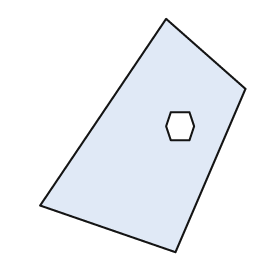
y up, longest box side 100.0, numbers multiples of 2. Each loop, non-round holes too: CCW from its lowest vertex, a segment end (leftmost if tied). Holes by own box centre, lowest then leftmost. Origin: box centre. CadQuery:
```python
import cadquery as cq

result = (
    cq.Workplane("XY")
    .moveTo(14.0, -50.0)
    .lineTo(44.0, 20.0)
    .lineTo(10.0, 50.0)
    .lineTo(-44.0, -30.0)
    .close()
    .moveTo(12.0, -2.0)
    .lineTo(20.0, -2.0)
    .lineTo(22.0, 4.0)
    .lineTo(20.0, 10.0)
    .lineTo(12.0, 10.0)
    .lineTo(10.0, 4.0)
    .close()
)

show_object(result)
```